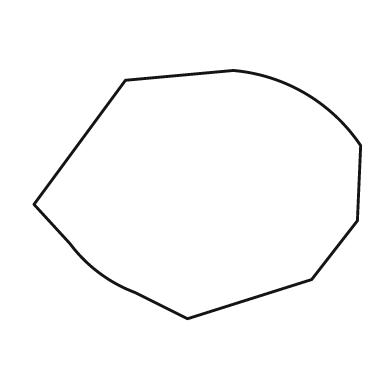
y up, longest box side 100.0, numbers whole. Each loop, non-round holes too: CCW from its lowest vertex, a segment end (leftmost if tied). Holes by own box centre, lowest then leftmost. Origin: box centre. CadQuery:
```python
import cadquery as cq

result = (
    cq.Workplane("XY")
    .moveTo(-3.0, -38.0)
    .lineTo(35.0, -26.0)
    .lineTo(49.0, -8.0)
    .lineTo(50.0, 15.0)
    .threePointArc((33.0, 31.0), (11.0, 38.0))
    .lineTo(-22.0, 35.0)
    .lineTo(-50.0, -3.0)
    .lineTo(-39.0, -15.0)
    .threePointArc((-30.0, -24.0), (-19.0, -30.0))
    .close()
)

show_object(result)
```